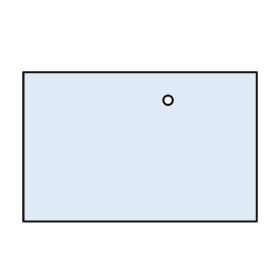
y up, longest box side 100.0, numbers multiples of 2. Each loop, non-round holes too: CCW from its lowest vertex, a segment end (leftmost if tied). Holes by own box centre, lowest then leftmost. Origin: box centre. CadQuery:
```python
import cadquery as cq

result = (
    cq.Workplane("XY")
    .moveTo(-50.0, -32.0)
    .lineTo(50.0, -32.0)
    .lineTo(50.0, 32.0)
    .lineTo(-50.0, 32.0)
    .close()
    .moveTo(12.0, 20.0)
    .circle(2.0)
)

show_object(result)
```